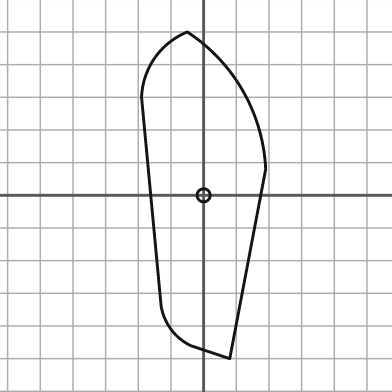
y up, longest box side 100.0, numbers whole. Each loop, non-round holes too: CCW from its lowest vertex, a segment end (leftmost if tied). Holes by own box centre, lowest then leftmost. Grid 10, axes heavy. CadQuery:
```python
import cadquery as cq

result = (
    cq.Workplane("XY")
    .moveTo(8.0, -50.0)
    .lineTo(19.0, 8.0)
    .threePointArc((12.0, 32.0), (-5.0, 50.0))
    .threePointArc((-15.0, 42.0), (-19.0, 30.0))
    .lineTo(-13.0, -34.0)
    .threePointArc((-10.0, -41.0), (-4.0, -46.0))
    .close()
    .moveTo(0.0, 0.0)
    .circle(2.0)
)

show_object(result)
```